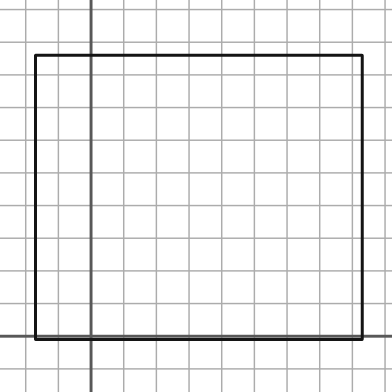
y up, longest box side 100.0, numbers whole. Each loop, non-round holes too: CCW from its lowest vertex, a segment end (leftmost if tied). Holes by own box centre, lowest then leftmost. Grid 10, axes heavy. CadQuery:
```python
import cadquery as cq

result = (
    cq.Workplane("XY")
    .moveTo(-17.0, -1.0)
    .lineTo(83.0, -1.0)
    .lineTo(83.0, 86.0)
    .lineTo(-17.0, 86.0)
    .close()
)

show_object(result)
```